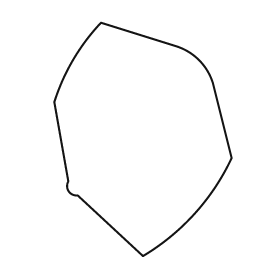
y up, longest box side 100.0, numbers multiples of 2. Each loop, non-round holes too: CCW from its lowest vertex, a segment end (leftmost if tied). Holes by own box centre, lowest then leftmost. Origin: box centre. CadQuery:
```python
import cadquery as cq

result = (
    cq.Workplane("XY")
    .moveTo(0.0, -50.0)
    .threePointArc((22.0, -32.0), (38.0, -8.0))
    .lineTo(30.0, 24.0)
    .threePointArc((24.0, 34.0), (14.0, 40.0))
    .lineTo(-18.0, 50.0)
    .threePointArc((-30.0, 34.0), (-38.0, 16.0))
    .lineTo(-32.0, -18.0)
    .threePointArc((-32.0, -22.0), (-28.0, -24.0))
    .close()
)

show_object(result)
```